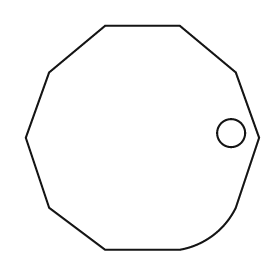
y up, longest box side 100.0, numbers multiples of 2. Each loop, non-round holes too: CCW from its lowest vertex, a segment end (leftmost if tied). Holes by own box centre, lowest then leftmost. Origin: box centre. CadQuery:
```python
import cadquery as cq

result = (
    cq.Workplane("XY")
    .moveTo(-16.0, -48.0)
    .lineTo(16.0, -48.0)
    .threePointArc((30.0, -42.0), (40.0, -30.0))
    .lineTo(50.0, 0.0)
    .lineTo(40.0, 28.0)
    .lineTo(16.0, 48.0)
    .lineTo(-16.0, 48.0)
    .lineTo(-40.0, 28.0)
    .lineTo(-50.0, 0.0)
    .lineTo(-40.0, -30.0)
    .close()
    .moveTo(38.0, 2.0)
    .circle(6.0)
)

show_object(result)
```